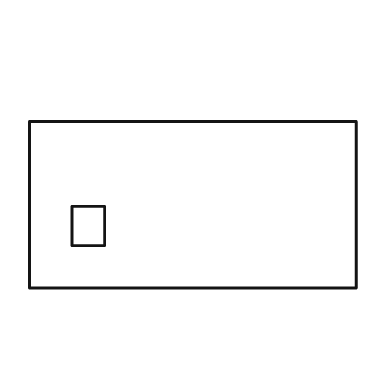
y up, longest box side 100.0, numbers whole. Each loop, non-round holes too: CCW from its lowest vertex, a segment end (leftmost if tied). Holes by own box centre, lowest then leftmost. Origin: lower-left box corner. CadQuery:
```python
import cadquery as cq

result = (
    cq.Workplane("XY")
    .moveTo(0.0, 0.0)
    .lineTo(100.0, 0.0)
    .lineTo(100.0, 51.0)
    .lineTo(0.0, 51.0)
    .close()
    .moveTo(13.0, 13.0)
    .lineTo(23.0, 13.0)
    .lineTo(23.0, 25.0)
    .lineTo(13.0, 25.0)
    .close()
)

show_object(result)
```